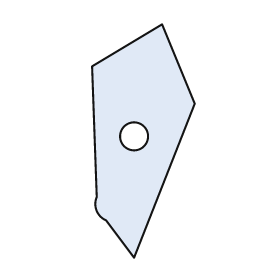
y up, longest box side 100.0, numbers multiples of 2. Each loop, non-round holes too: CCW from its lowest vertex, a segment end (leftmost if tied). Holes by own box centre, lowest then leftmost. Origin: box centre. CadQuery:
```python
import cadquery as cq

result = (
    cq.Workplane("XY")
    .moveTo(-4.0, -50.0)
    .lineTo(22.0, 16.0)
    .lineTo(8.0, 50.0)
    .lineTo(-22.0, 32.0)
    .lineTo(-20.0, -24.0)
    .threePointArc((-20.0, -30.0), (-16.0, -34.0))
    .close()
    .moveTo(-4.0, 2.0)
    .circle(6.0)
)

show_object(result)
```